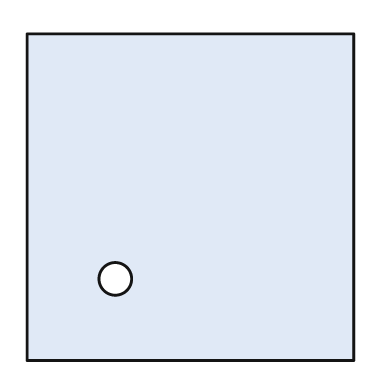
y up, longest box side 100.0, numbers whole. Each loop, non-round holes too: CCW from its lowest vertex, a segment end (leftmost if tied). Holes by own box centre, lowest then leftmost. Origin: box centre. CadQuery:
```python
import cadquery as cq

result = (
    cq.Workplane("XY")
    .moveTo(-50.0, -50.0)
    .lineTo(50.0, -50.0)
    .lineTo(50.0, 50.0)
    .lineTo(-50.0, 50.0)
    .close()
    .moveTo(-23.0, -25.0)
    .circle(5.0)
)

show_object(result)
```